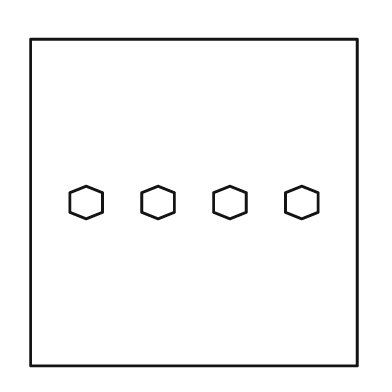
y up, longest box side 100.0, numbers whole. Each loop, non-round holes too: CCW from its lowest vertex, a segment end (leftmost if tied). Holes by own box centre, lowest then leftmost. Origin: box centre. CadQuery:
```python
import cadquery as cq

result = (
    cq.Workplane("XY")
    .moveTo(-50.0, -50.0)
    .lineTo(50.0, -50.0)
    .lineTo(50.0, 50.0)
    .lineTo(-50.0, 50.0)
    .close()
    .moveTo(-33.0, -5.0)
    .lineTo(-28.0, -3.0)
    .lineTo(-28.0, 3.0)
    .lineTo(-33.0, 5.0)
    .lineTo(-38.0, 3.0)
    .lineTo(-38.0, -3.0)
    .close()
    .moveTo(-11.0, -5.0)
    .lineTo(-6.0, -3.0)
    .lineTo(-6.0, 3.0)
    .lineTo(-11.0, 5.0)
    .lineTo(-16.0, 3.0)
    .lineTo(-16.0, -3.0)
    .close()
    .moveTo(11.0, -5.0)
    .lineTo(16.0, -3.0)
    .lineTo(16.0, 3.0)
    .lineTo(11.0, 5.0)
    .lineTo(6.0, 3.0)
    .lineTo(6.0, -3.0)
    .close()
    .moveTo(33.0, -5.0)
    .lineTo(38.0, -3.0)
    .lineTo(38.0, 3.0)
    .lineTo(33.0, 5.0)
    .lineTo(28.0, 3.0)
    .lineTo(28.0, -3.0)
    .close()
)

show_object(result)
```